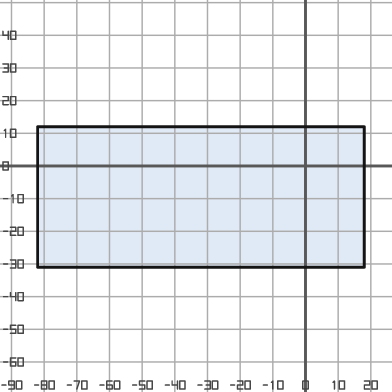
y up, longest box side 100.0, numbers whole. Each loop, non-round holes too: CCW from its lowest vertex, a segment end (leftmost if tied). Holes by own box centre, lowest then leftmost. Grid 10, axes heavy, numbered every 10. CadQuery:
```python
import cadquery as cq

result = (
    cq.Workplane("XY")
    .moveTo(-82.0, -31.0)
    .lineTo(18.0, -31.0)
    .lineTo(18.0, 12.0)
    .lineTo(-82.0, 12.0)
    .close()
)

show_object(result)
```